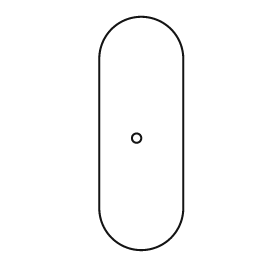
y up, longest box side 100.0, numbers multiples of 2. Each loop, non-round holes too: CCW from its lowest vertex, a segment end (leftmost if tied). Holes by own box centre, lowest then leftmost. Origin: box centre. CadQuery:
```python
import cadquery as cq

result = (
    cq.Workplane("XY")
    .moveTo(-18.0, -32.0)
    .threePointArc((0.0, -50.0), (18.0, -32.0))
    .lineTo(18.0, 32.0)
    .threePointArc((0.0, 50.0), (-18.0, 32.0))
    .close()
    .moveTo(-2.0, -2.0)
    .circle(2.0)
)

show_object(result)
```